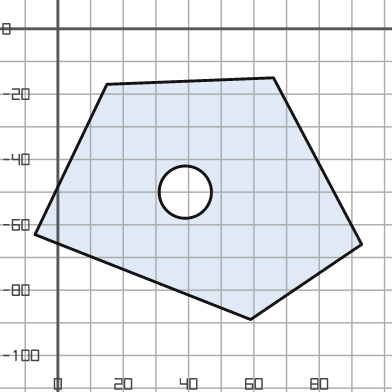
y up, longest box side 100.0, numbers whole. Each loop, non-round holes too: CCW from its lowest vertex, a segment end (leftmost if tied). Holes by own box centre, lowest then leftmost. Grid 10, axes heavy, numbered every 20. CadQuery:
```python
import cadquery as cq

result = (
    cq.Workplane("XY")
    .moveTo(59.0, -89.0)
    .lineTo(93.0, -66.0)
    .lineTo(66.0, -15.0)
    .lineTo(15.0, -17.0)
    .lineTo(-7.0, -63.0)
    .close()
    .moveTo(39.0, -50.0)
    .circle(8.0)
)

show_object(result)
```